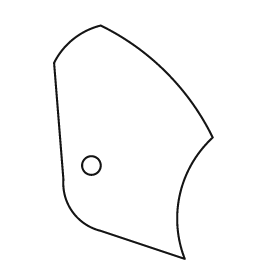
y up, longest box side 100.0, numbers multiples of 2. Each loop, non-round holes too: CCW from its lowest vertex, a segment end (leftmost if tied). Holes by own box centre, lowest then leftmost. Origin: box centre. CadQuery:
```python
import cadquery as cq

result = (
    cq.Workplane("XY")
    .moveTo(22.0, -50.0)
    .threePointArc((20.0, -22.0), (34.0, 2.0))
    .threePointArc((14.0, 30.0), (-14.0, 50.0))
    .threePointArc((-26.0, 44.0), (-34.0, 34.0))
    .lineTo(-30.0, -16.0)
    .threePointArc((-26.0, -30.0), (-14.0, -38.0))
    .close()
    .moveTo(-18.0, -10.0)
    .circle(4.0)
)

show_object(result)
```